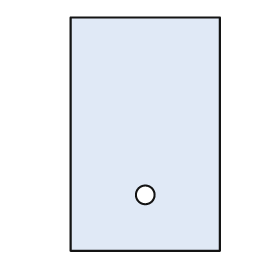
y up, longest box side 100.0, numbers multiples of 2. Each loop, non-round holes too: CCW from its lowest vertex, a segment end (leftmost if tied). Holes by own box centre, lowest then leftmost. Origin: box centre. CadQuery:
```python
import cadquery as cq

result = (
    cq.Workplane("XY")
    .moveTo(-32.0, -50.0)
    .lineTo(32.0, -50.0)
    .lineTo(32.0, 50.0)
    .lineTo(-32.0, 50.0)
    .close()
    .moveTo(0.0, -26.0)
    .circle(4.0)
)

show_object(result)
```